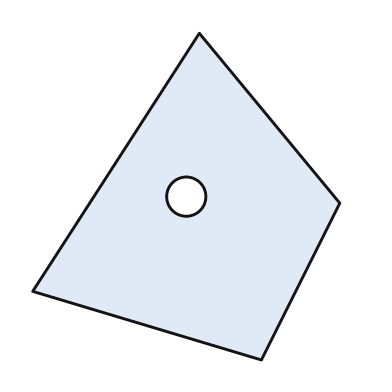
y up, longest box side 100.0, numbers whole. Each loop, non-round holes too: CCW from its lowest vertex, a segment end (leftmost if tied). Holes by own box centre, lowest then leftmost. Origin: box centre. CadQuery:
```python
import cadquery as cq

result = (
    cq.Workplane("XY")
    .moveTo(23.0, -50.0)
    .lineTo(47.0, -2.0)
    .lineTo(4.0, 50.0)
    .lineTo(-47.0, -29.0)
    .close()
    .moveTo(0.0, 0.0)
    .circle(6.0)
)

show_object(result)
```